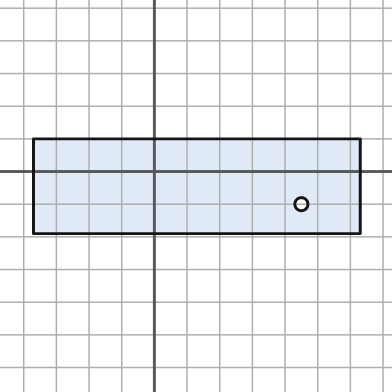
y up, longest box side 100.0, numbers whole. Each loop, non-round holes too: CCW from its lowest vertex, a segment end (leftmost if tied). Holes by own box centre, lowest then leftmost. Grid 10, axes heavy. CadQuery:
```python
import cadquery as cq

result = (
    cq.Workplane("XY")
    .moveTo(-37.0, -19.0)
    .lineTo(63.0, -19.0)
    .lineTo(63.0, 10.0)
    .lineTo(-37.0, 10.0)
    .close()
    .moveTo(45.0, -10.0)
    .circle(2.0)
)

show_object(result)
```